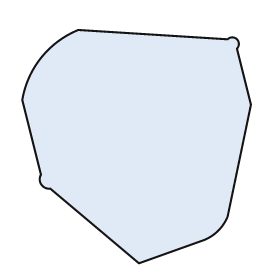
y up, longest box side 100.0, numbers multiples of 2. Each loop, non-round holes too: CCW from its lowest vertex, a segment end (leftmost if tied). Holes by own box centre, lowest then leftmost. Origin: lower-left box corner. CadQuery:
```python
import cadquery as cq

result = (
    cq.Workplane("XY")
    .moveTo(50.0, 0.0)
    .lineTo(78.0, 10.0)
    .threePointArc((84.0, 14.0), (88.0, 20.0))
    .lineTo(98.0, 68.0)
    .lineTo(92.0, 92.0)
    .threePointArc((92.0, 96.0), (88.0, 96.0))
    .lineTo(24.0, 100.0)
    .threePointArc((8.0, 88.0), (0.0, 70.0))
    .lineTo(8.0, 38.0)
    .threePointArc((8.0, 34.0), (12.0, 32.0))
    .close()
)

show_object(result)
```